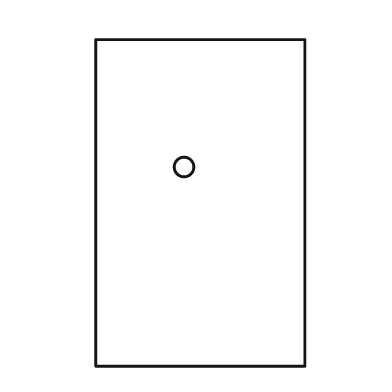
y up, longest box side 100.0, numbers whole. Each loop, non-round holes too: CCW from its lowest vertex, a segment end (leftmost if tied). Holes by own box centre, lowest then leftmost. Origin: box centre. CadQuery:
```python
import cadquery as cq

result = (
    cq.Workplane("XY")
    .moveTo(-32.0, -50.0)
    .lineTo(32.0, -50.0)
    .lineTo(32.0, 50.0)
    .lineTo(-32.0, 50.0)
    .close()
    .moveTo(-5.0, 11.0)
    .circle(3.0)
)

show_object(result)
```